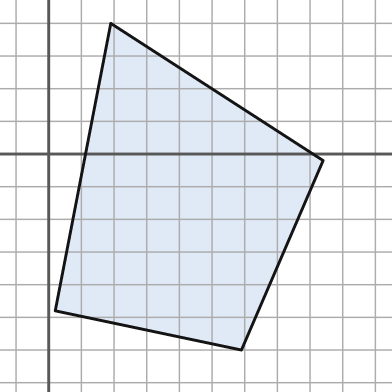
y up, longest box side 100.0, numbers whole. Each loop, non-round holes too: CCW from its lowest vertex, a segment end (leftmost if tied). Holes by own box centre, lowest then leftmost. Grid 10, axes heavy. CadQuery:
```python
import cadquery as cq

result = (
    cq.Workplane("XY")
    .moveTo(59.0, -60.0)
    .lineTo(84.0, -2.0)
    .lineTo(19.0, 40.0)
    .lineTo(2.0, -48.0)
    .close()
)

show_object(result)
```